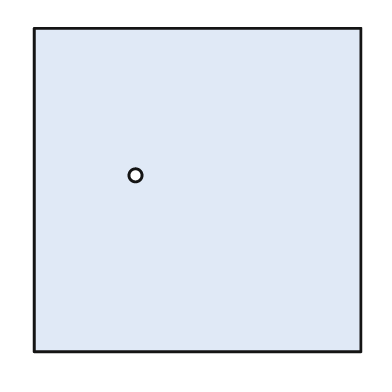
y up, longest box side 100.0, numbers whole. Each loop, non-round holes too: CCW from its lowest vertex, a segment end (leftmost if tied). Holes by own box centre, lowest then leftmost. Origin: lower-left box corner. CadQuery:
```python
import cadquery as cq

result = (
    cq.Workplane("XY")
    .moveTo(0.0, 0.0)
    .lineTo(100.0, 0.0)
    .lineTo(100.0, 99.0)
    .lineTo(0.0, 99.0)
    .close()
    .moveTo(31.0, 54.0)
    .circle(2.0)
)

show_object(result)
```